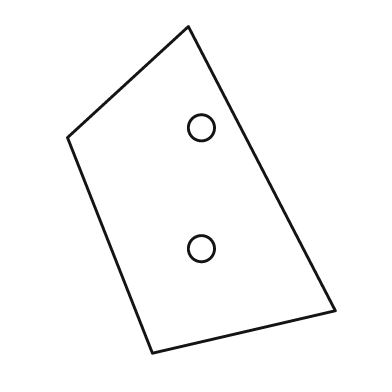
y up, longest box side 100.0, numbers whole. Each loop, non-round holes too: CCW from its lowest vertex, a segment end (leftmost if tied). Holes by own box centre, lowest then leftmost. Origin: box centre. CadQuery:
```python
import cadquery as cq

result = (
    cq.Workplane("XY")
    .moveTo(-15.0, -50.0)
    .lineTo(41.0, -37.0)
    .lineTo(-4.0, 50.0)
    .lineTo(-41.0, 16.0)
    .close()
    .moveTo(0.0, -18.0)
    .circle(4.0)
    .moveTo(0.0, 19.0)
    .circle(4.0)
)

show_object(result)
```